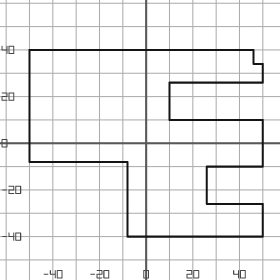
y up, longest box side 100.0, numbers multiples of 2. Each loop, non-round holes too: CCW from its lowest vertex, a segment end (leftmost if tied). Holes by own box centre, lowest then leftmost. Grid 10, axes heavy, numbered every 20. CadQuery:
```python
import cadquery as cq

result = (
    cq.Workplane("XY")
    .moveTo(-8.0, -40.0)
    .lineTo(50.0, -40.0)
    .lineTo(50.0, -26.0)
    .lineTo(26.0, -26.0)
    .lineTo(26.0, -10.0)
    .lineTo(50.0, -10.0)
    .lineTo(50.0, 10.0)
    .lineTo(10.0, 10.0)
    .lineTo(10.0, 26.0)
    .lineTo(50.0, 26.0)
    .lineTo(50.0, 34.0)
    .lineTo(46.0, 34.0)
    .lineTo(46.0, 40.0)
    .lineTo(-50.0, 40.0)
    .lineTo(-50.0, -8.0)
    .lineTo(-8.0, -8.0)
    .close()
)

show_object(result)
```